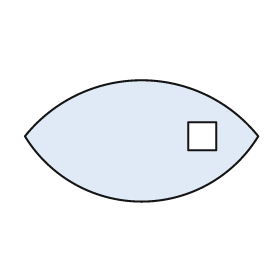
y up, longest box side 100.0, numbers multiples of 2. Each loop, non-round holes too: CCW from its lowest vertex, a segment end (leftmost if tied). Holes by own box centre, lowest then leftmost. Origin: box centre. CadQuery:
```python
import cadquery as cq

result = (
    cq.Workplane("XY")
    .moveTo(-50.0, 2.0)
    .threePointArc((0.0, -26.0), (50.0, 2.0))
    .threePointArc((0.0, 26.0), (-50.0, 2.0))
    .close()
    .moveTo(20.0, -4.0)
    .lineTo(32.0, -4.0)
    .lineTo(32.0, 8.0)
    .lineTo(20.0, 8.0)
    .close()
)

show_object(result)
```